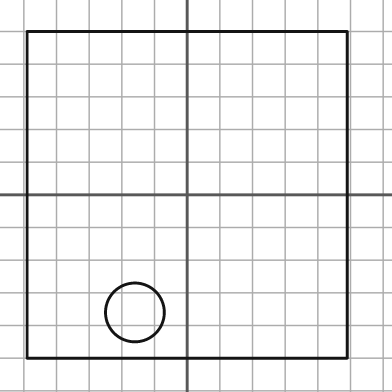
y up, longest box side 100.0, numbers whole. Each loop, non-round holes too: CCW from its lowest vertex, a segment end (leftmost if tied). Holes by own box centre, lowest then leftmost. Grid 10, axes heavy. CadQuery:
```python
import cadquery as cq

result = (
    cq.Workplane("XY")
    .moveTo(-49.0, -50.0)
    .lineTo(49.0, -50.0)
    .lineTo(49.0, 50.0)
    .lineTo(-49.0, 50.0)
    .close()
    .moveTo(-16.0, -36.0)
    .circle(9.0)
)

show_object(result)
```